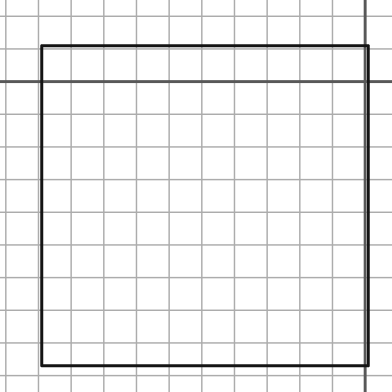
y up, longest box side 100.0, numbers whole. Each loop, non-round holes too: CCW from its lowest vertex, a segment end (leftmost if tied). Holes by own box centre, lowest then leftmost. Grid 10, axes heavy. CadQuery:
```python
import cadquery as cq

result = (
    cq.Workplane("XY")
    .moveTo(-99.0, -87.0)
    .lineTo(1.0, -87.0)
    .lineTo(1.0, 11.0)
    .lineTo(-99.0, 11.0)
    .close()
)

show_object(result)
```